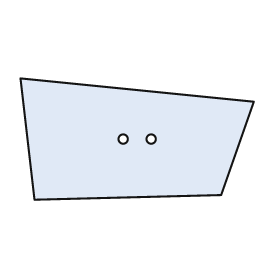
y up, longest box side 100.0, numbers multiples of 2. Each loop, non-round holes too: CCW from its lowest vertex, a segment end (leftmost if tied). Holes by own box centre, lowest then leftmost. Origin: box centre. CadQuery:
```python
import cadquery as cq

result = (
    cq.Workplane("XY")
    .moveTo(-44.0, -26.0)
    .lineTo(36.0, -24.0)
    .lineTo(50.0, 16.0)
    .lineTo(-50.0, 26.0)
    .close()
    .moveTo(-6.0, 0.0)
    .circle(2.0)
    .moveTo(6.0, 0.0)
    .circle(2.0)
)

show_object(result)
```